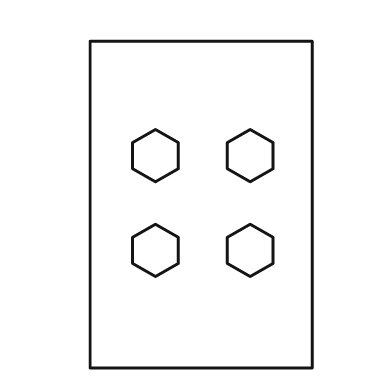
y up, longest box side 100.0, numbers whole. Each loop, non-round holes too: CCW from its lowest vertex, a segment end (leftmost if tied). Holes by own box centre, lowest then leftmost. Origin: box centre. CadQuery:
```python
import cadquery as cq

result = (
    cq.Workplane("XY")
    .moveTo(-34.0, -50.0)
    .lineTo(34.0, -50.0)
    .lineTo(34.0, 50.0)
    .lineTo(-34.0, 50.0)
    .close()
    .moveTo(-14.0, -22.0)
    .lineTo(-7.0, -18.0)
    .lineTo(-7.0, -10.0)
    .lineTo(-14.0, -6.0)
    .lineTo(-21.0, -10.0)
    .lineTo(-21.0, -18.0)
    .close()
    .moveTo(15.0, -22.0)
    .lineTo(22.0, -18.0)
    .lineTo(22.0, -10.0)
    .lineTo(15.0, -6.0)
    .lineTo(8.0, -10.0)
    .lineTo(8.0, -18.0)
    .close()
    .moveTo(-14.0, 7.0)
    .lineTo(-7.0, 11.0)
    .lineTo(-7.0, 19.0)
    .lineTo(-14.0, 23.0)
    .lineTo(-21.0, 19.0)
    .lineTo(-21.0, 11.0)
    .close()
    .moveTo(15.0, 7.0)
    .lineTo(22.0, 11.0)
    .lineTo(22.0, 19.0)
    .lineTo(15.0, 23.0)
    .lineTo(8.0, 19.0)
    .lineTo(8.0, 11.0)
    .close()
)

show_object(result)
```